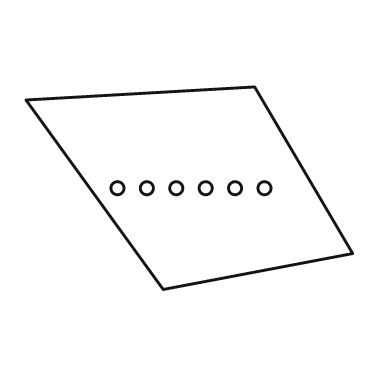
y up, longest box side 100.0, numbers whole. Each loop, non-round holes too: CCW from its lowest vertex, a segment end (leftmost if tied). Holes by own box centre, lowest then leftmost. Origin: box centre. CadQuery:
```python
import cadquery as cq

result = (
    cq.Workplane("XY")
    .moveTo(-8.0, -31.0)
    .lineTo(50.0, -20.0)
    .lineTo(20.0, 31.0)
    .lineTo(-50.0, 27.0)
    .close()
    .moveTo(-22.0, 0.0)
    .circle(2.0)
    .moveTo(-13.0, 0.0)
    .circle(2.0)
    .moveTo(-4.0, 0.0)
    .circle(2.0)
    .moveTo(5.0, 0.0)
    .circle(2.0)
    .moveTo(14.0, 0.0)
    .circle(2.0)
    .moveTo(23.0, 0.0)
    .circle(2.0)
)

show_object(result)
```